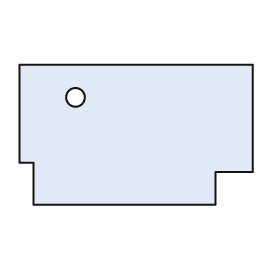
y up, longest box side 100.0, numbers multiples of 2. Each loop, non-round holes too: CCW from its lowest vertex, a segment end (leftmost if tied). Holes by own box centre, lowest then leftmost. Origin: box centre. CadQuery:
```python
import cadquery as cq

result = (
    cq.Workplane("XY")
    .moveTo(-44.0, -30.0)
    .lineTo(34.0, -30.0)
    .lineTo(34.0, -16.0)
    .lineTo(50.0, -16.0)
    .lineTo(50.0, 30.0)
    .lineTo(-50.0, 30.0)
    .lineTo(-50.0, -12.0)
    .lineTo(-44.0, -12.0)
    .close()
    .moveTo(-26.0, 16.0)
    .circle(4.0)
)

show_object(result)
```